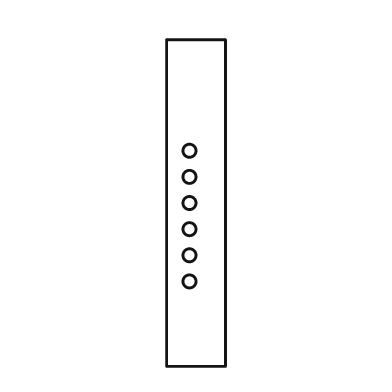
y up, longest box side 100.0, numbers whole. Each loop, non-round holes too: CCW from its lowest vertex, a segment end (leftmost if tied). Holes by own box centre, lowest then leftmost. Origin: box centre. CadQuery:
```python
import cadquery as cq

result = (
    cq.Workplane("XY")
    .moveTo(-9.0, -50.0)
    .lineTo(9.0, -50.0)
    .lineTo(9.0, 50.0)
    .lineTo(-9.0, 50.0)
    .close()
    .moveTo(-2.0, -24.0)
    .circle(2.0)
    .moveTo(-2.0, -16.0)
    .circle(2.0)
    .moveTo(-2.0, -8.0)
    .circle(2.0)
    .moveTo(-2.0, 0.0)
    .circle(2.0)
    .moveTo(-2.0, 8.0)
    .circle(2.0)
    .moveTo(-2.0, 16.0)
    .circle(2.0)
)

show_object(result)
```